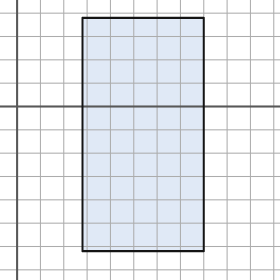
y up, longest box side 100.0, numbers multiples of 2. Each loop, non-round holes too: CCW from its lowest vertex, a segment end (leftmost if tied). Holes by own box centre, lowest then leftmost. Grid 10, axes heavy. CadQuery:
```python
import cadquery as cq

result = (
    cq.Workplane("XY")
    .moveTo(28.0, -62.0)
    .lineTo(80.0, -62.0)
    .lineTo(80.0, 38.0)
    .lineTo(28.0, 38.0)
    .close()
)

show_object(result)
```